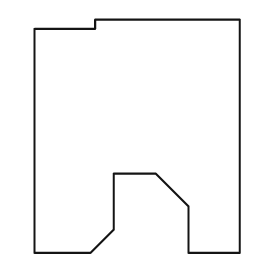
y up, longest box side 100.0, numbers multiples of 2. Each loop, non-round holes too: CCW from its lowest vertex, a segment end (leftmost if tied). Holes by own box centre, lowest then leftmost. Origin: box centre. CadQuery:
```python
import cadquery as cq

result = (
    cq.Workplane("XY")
    .moveTo(-44.0, -50.0)
    .lineTo(-20.0, -50.0)
    .lineTo(-10.0, -40.0)
    .lineTo(-10.0, -16.0)
    .lineTo(8.0, -16.0)
    .lineTo(22.0, -30.0)
    .lineTo(22.0, -50.0)
    .lineTo(44.0, -50.0)
    .lineTo(44.0, 50.0)
    .lineTo(-18.0, 50.0)
    .lineTo(-18.0, 46.0)
    .lineTo(-44.0, 46.0)
    .close()
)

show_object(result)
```